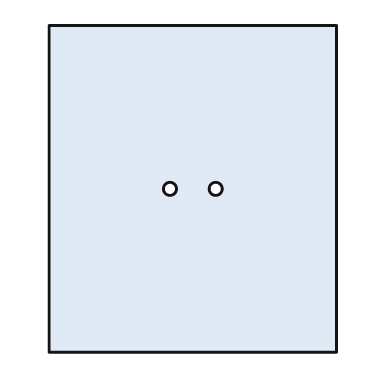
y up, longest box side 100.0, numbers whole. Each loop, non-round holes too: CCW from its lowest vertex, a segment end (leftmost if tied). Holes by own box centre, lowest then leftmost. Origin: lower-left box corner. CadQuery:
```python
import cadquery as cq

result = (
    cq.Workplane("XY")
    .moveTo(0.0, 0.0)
    .lineTo(88.0, 0.0)
    .lineTo(88.0, 100.0)
    .lineTo(0.0, 100.0)
    .close()
    .moveTo(37.0, 50.0)
    .circle(2.0)
    .moveTo(51.0, 50.0)
    .circle(2.0)
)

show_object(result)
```